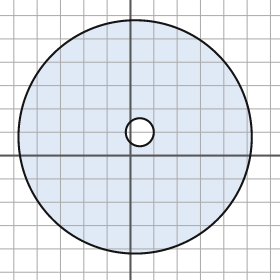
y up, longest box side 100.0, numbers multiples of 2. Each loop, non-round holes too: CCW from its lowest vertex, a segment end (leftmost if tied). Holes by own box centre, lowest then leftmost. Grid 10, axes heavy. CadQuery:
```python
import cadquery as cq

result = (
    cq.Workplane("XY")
    .moveTo(2.0, 8.0)
    .circle(50.0)
    .moveTo(4.0, 10.0)
    .circle(6.0)
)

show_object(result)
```